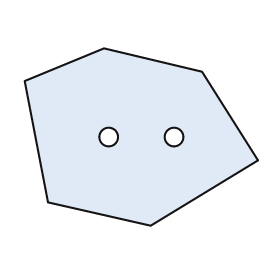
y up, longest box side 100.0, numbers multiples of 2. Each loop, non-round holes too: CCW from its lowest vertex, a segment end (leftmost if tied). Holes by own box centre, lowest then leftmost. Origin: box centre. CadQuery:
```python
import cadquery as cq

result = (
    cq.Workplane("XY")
    .moveTo(4.0, -38.0)
    .lineTo(50.0, -10.0)
    .lineTo(26.0, 28.0)
    .lineTo(-16.0, 38.0)
    .lineTo(-50.0, 24.0)
    .lineTo(-40.0, -28.0)
    .close()
    .moveTo(-14.0, 0.0)
    .circle(4.0)
    .moveTo(14.0, 0.0)
    .circle(4.0)
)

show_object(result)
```